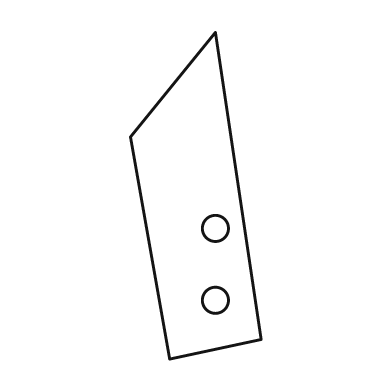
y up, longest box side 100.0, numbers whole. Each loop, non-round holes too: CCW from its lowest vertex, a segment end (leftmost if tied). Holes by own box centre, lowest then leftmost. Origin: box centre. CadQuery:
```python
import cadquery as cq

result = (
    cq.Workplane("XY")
    .moveTo(-8.0, -50.0)
    .lineTo(20.0, -44.0)
    .lineTo(6.0, 50.0)
    .lineTo(-20.0, 18.0)
    .close()
    .moveTo(6.0, -32.0)
    .circle(4.0)
    .moveTo(6.0, -10.0)
    .circle(4.0)
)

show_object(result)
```